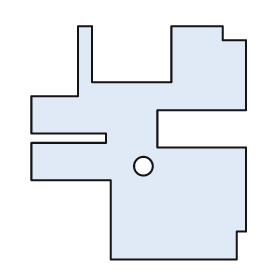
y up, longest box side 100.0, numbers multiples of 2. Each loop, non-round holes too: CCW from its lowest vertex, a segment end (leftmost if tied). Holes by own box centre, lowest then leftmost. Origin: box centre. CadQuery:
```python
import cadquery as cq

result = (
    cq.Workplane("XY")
    .moveTo(-12.0, -50.0)
    .lineTo(42.0, -50.0)
    .lineTo(42.0, -38.0)
    .lineTo(46.0, -38.0)
    .lineTo(46.0, -2.0)
    .lineTo(8.0, -2.0)
    .lineTo(8.0, 14.0)
    .lineTo(46.0, 14.0)
    .lineTo(46.0, 44.0)
    .lineTo(36.0, 44.0)
    .lineTo(36.0, 50.0)
    .lineTo(14.0, 50.0)
    .lineTo(14.0, 26.0)
    .lineTo(-20.0, 26.0)
    .lineTo(-20.0, 50.0)
    .lineTo(-26.0, 50.0)
    .lineTo(-26.0, 20.0)
    .lineTo(-46.0, 20.0)
    .lineTo(-46.0, 4.0)
    .lineTo(-14.0, 4.0)
    .lineTo(-14.0, 0.0)
    .lineTo(-46.0, 0.0)
    .lineTo(-46.0, -16.0)
    .lineTo(-12.0, -16.0)
    .close()
    .moveTo(2.0, -10.0)
    .circle(4.0)
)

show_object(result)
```